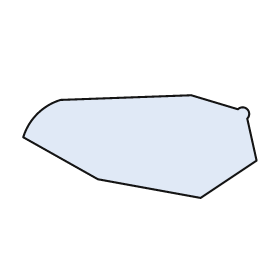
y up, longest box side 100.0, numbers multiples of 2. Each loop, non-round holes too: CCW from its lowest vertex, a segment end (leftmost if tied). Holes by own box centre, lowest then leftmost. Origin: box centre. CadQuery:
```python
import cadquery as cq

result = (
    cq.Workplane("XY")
    .moveTo(26.0, -22.0)
    .lineTo(50.0, -6.0)
    .lineTo(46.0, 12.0)
    .threePointArc((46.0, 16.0), (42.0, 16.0))
    .lineTo(22.0, 22.0)
    .lineTo(-34.0, 20.0)
    .threePointArc((-44.0, 14.0), (-50.0, 4.0))
    .lineTo(-18.0, -14.0)
    .close()
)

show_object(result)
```